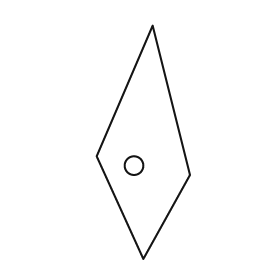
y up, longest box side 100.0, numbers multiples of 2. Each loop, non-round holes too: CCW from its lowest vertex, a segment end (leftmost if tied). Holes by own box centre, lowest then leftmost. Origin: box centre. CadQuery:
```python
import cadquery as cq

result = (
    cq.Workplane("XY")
    .moveTo(0.0, -50.0)
    .lineTo(20.0, -14.0)
    .lineTo(4.0, 50.0)
    .lineTo(-20.0, -6.0)
    .close()
    .moveTo(-4.0, -10.0)
    .circle(4.0)
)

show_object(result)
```